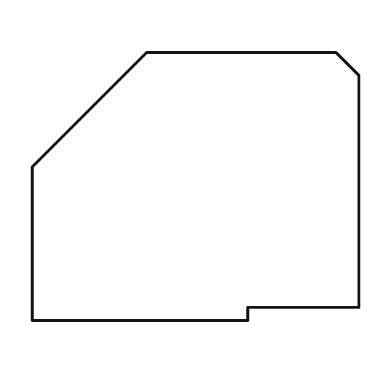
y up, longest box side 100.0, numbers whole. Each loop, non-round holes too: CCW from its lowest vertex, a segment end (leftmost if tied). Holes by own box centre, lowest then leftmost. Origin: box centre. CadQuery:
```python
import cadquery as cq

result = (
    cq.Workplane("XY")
    .moveTo(-50.0, -41.0)
    .lineTo(16.0, -41.0)
    .lineTo(16.0, -37.0)
    .lineTo(50.0, -37.0)
    .lineTo(50.0, 34.0)
    .lineTo(43.0, 41.0)
    .lineTo(-15.0, 41.0)
    .lineTo(-50.0, 6.0)
    .close()
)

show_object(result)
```